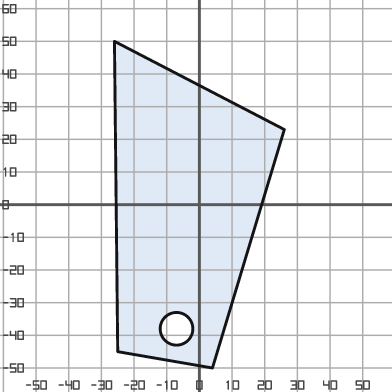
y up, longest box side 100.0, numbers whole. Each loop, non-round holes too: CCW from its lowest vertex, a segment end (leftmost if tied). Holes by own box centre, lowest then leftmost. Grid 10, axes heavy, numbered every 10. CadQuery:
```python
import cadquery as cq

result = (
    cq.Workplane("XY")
    .moveTo(4.0, -50.0)
    .lineTo(26.0, 23.0)
    .lineTo(-26.0, 50.0)
    .lineTo(-25.0, -45.0)
    .close()
    .moveTo(-7.0, -38.0)
    .circle(5.0)
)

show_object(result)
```